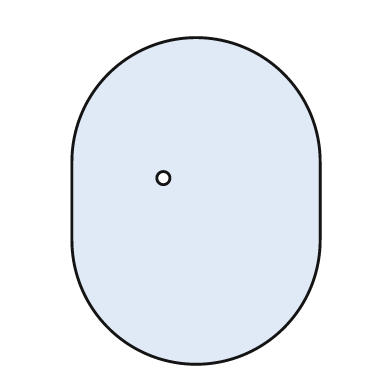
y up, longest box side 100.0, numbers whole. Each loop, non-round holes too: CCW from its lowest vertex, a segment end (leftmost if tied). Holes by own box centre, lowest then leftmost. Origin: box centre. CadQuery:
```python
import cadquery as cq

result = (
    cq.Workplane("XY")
    .moveTo(-38.0, -12.0)
    .threePointArc((0.0, -50.0), (38.0, -12.0))
    .lineTo(38.0, 12.0)
    .threePointArc((0.0, 50.0), (-38.0, 12.0))
    .close()
    .moveTo(-10.0, 7.0)
    .circle(2.0)
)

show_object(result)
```